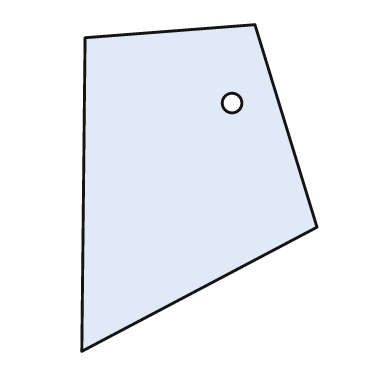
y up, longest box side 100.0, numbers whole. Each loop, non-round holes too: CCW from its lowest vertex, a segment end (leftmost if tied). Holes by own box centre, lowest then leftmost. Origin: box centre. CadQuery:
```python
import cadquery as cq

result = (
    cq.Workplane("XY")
    .moveTo(-36.0, -50.0)
    .lineTo(36.0, -12.0)
    .lineTo(17.0, 50.0)
    .lineTo(-35.0, 46.0)
    .close()
    .moveTo(10.0, 26.0)
    .circle(3.0)
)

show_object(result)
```